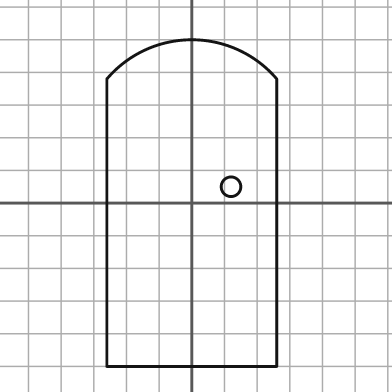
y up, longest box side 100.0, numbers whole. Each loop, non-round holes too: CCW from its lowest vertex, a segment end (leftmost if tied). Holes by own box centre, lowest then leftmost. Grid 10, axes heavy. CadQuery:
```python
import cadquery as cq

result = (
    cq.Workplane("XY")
    .moveTo(-26.0, -50.0)
    .lineTo(26.0, -50.0)
    .lineTo(26.0, 38.0)
    .threePointArc((0.0, 50.0), (-26.0, 38.0))
    .close()
    .moveTo(12.0, 5.0)
    .circle(3.0)
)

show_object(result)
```